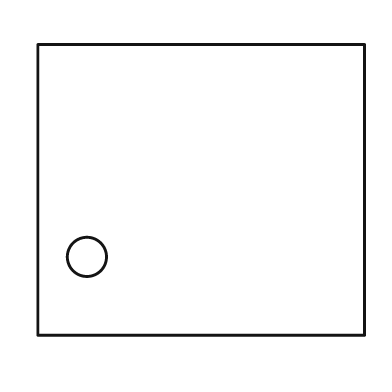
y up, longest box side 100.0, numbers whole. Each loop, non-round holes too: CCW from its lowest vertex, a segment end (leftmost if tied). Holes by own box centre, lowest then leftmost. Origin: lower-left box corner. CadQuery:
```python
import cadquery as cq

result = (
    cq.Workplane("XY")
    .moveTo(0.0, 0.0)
    .lineTo(100.0, 0.0)
    .lineTo(100.0, 89.0)
    .lineTo(0.0, 89.0)
    .close()
    .moveTo(15.0, 24.0)
    .circle(6.0)
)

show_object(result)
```